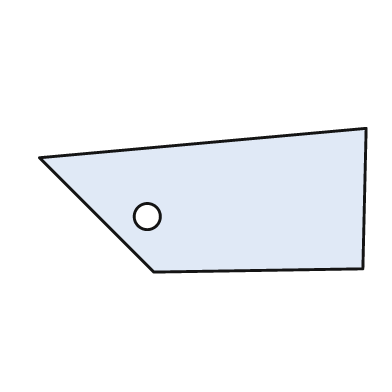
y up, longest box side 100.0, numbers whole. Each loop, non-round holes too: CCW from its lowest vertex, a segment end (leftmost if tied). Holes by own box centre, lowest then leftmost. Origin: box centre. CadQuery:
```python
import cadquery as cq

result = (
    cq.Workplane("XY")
    .moveTo(-15.0, -22.0)
    .lineTo(49.0, -21.0)
    .lineTo(50.0, 22.0)
    .lineTo(-50.0, 13.0)
    .close()
    .moveTo(-17.0, -5.0)
    .circle(4.0)
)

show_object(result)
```